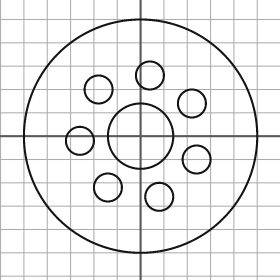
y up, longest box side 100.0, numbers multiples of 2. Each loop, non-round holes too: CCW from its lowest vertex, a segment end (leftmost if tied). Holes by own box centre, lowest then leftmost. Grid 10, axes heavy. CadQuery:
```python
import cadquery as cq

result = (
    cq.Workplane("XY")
    .moveTo(0.0, 0.0)
    .circle(50.0)
    .moveTo(8.0, -26.0)
    .circle(6.0)
    .moveTo(-14.0, -22.0)
    .circle(6.0)
    .moveTo(24.0, -10.0)
    .circle(6.0)
    .moveTo(-26.0, -2.0)
    .circle(6.0)
    .moveTo(0.0, 0.0)
    .circle(14.0)
    .moveTo(22.0, 14.0)
    .circle(6.0)
    .moveTo(-18.0, 20.0)
    .circle(6.0)
    .moveTo(4.0, 26.0)
    .circle(6.0)
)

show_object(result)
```